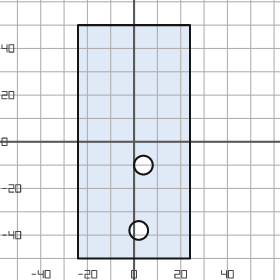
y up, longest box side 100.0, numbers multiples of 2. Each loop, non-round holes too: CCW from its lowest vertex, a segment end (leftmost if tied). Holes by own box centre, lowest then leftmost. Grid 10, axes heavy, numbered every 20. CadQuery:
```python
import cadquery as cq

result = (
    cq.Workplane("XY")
    .moveTo(-24.0, -50.0)
    .lineTo(24.0, -50.0)
    .lineTo(24.0, 50.0)
    .lineTo(-24.0, 50.0)
    .close()
    .moveTo(2.0, -38.0)
    .circle(4.0)
    .moveTo(4.0, -10.0)
    .circle(4.0)
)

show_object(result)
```